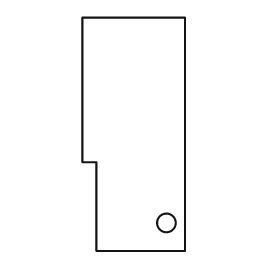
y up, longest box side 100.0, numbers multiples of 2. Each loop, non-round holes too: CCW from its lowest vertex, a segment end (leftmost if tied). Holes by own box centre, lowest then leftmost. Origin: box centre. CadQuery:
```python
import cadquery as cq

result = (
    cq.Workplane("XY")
    .moveTo(-16.0, -50.0)
    .lineTo(22.0, -50.0)
    .lineTo(22.0, 50.0)
    .lineTo(-22.0, 50.0)
    .lineTo(-22.0, -12.0)
    .lineTo(-16.0, -12.0)
    .close()
    .moveTo(14.0, -38.0)
    .circle(4.0)
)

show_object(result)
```